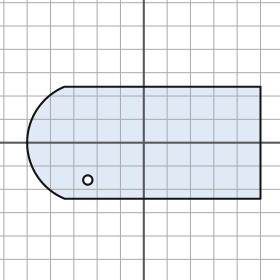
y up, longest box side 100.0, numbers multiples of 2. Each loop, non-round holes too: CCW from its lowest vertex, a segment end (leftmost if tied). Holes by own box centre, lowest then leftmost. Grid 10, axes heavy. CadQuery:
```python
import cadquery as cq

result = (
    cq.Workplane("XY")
    .moveTo(-34.0, -24.0)
    .lineTo(50.0, -24.0)
    .lineTo(50.0, 24.0)
    .lineTo(-34.0, 24.0)
    .threePointArc((-50.0, 0.0), (-34.0, -24.0))
    .close()
    .moveTo(-24.0, -16.0)
    .circle(2.0)
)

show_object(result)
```